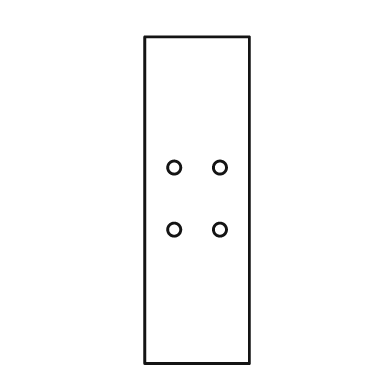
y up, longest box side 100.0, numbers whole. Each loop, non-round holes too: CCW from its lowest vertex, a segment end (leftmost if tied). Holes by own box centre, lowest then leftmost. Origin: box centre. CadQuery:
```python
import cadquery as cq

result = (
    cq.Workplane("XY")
    .moveTo(-16.0, -50.0)
    .lineTo(16.0, -50.0)
    .lineTo(16.0, 50.0)
    .lineTo(-16.0, 50.0)
    .close()
    .moveTo(-7.0, -9.0)
    .circle(2.0)
    .moveTo(7.0, -9.0)
    .circle(2.0)
    .moveTo(-7.0, 10.0)
    .circle(2.0)
    .moveTo(7.0, 10.0)
    .circle(2.0)
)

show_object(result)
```